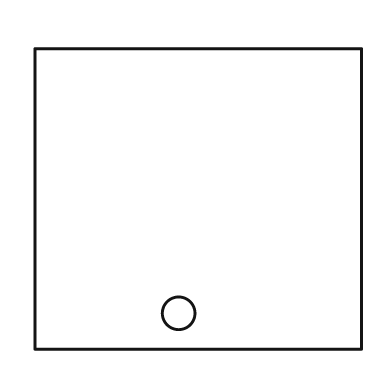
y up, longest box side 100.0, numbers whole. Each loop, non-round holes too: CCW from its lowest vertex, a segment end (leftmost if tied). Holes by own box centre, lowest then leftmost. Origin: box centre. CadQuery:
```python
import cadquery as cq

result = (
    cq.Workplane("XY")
    .moveTo(-50.0, -46.0)
    .lineTo(50.0, -46.0)
    .lineTo(50.0, 46.0)
    .lineTo(-50.0, 46.0)
    .close()
    .moveTo(-6.0, -35.0)
    .circle(5.0)
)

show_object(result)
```